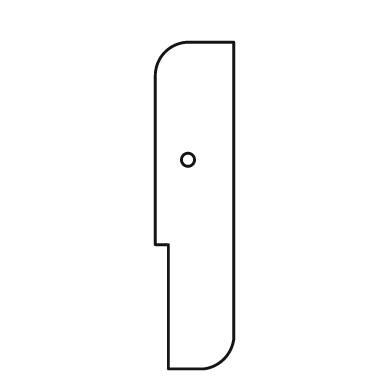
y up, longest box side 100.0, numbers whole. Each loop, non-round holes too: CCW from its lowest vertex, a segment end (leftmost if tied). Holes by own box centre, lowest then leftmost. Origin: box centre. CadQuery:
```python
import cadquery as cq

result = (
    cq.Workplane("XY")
    .moveTo(-8.0, -50.0)
    .lineTo(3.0, -50.0)
    .threePointArc((9.0, -47.0), (12.0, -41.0))
    .lineTo(12.0, 50.0)
    .lineTo(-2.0, 50.0)
    .threePointArc((-9.0, 47.0), (-12.0, 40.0))
    .lineTo(-12.0, -12.0)
    .lineTo(-8.0, -12.0)
    .close()
    .moveTo(-2.0, 14.0)
    .circle(2.0)
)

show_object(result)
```